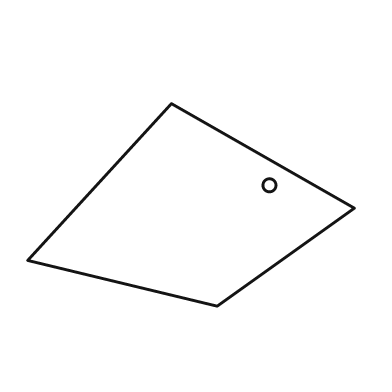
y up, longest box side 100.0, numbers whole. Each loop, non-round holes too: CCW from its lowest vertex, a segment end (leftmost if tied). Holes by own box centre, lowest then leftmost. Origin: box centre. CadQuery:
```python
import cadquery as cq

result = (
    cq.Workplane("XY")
    .moveTo(8.0, -31.0)
    .lineTo(50.0, -1.0)
    .lineTo(-6.0, 31.0)
    .lineTo(-50.0, -17.0)
    .close()
    .moveTo(24.0, 6.0)
    .circle(2.0)
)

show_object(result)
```